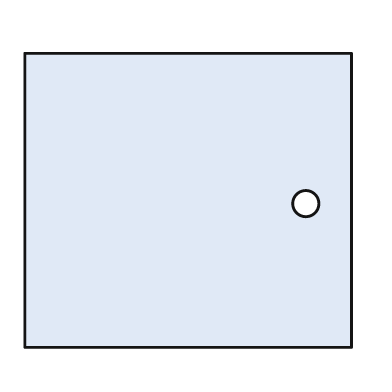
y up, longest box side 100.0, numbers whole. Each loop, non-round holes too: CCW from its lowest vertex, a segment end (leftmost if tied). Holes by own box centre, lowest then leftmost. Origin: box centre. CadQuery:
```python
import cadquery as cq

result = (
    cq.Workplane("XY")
    .moveTo(-50.0, -45.0)
    .lineTo(50.0, -45.0)
    .lineTo(50.0, 45.0)
    .lineTo(-50.0, 45.0)
    .close()
    .moveTo(36.0, -1.0)
    .circle(4.0)
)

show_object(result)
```